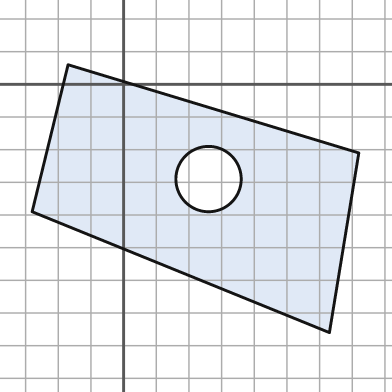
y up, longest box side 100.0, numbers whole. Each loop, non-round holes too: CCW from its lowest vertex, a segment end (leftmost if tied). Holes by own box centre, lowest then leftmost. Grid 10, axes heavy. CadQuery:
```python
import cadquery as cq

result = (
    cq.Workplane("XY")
    .moveTo(63.0, -76.0)
    .lineTo(72.0, -21.0)
    .lineTo(-17.0, 6.0)
    .lineTo(-28.0, -39.0)
    .close()
    .moveTo(26.0, -29.0)
    .circle(10.0)
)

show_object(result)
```